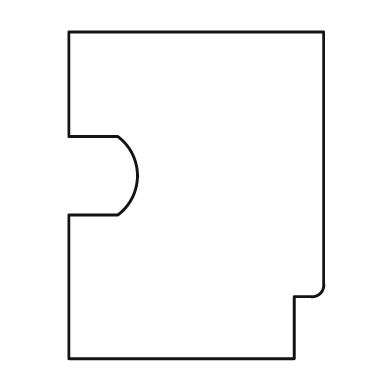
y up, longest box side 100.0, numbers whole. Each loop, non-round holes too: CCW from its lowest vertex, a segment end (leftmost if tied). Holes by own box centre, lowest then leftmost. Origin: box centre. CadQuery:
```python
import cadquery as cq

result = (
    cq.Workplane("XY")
    .moveTo(-39.0, -50.0)
    .lineTo(30.0, -50.0)
    .lineTo(30.0, -31.0)
    .lineTo(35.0, -31.0)
    .threePointArc((38.0, -30.0), (39.0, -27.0))
    .lineTo(39.0, 50.0)
    .lineTo(-39.0, 50.0)
    .lineTo(-39.0, 18.0)
    .lineTo(-24.0, 18.0)
    .threePointArc((-18.0, 6.0), (-24.0, -6.0))
    .lineTo(-39.0, -6.0)
    .close()
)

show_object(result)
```